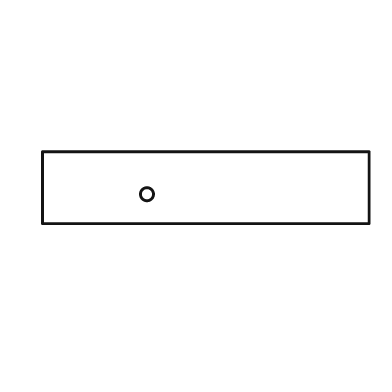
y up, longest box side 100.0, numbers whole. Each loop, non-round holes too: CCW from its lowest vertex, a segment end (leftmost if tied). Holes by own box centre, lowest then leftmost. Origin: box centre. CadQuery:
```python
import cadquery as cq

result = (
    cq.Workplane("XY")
    .moveTo(-50.0, -11.0)
    .lineTo(50.0, -11.0)
    .lineTo(50.0, 11.0)
    .lineTo(-50.0, 11.0)
    .close()
    .moveTo(-18.0, -2.0)
    .circle(2.0)
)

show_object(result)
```